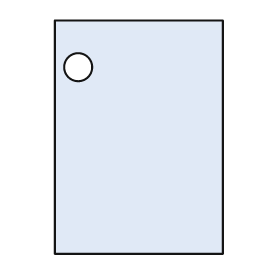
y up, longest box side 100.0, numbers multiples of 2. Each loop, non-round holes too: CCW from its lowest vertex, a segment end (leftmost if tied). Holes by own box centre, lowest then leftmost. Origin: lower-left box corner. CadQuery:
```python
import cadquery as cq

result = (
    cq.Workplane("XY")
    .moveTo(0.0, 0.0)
    .lineTo(72.0, 0.0)
    .lineTo(72.0, 100.0)
    .lineTo(0.0, 100.0)
    .close()
    .moveTo(10.0, 80.0)
    .circle(6.0)
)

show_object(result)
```